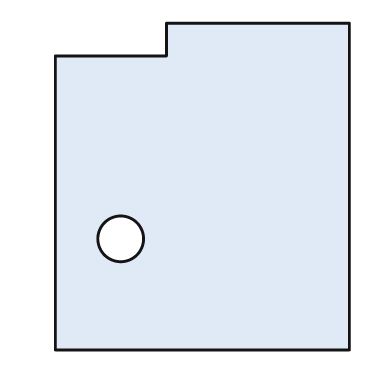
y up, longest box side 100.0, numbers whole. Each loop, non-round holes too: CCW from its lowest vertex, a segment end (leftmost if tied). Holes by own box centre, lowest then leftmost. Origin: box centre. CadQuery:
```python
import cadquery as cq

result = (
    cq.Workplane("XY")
    .moveTo(-45.0, -50.0)
    .lineTo(45.0, -50.0)
    .lineTo(45.0, 50.0)
    .lineTo(-11.0, 50.0)
    .lineTo(-11.0, 40.0)
    .lineTo(-45.0, 40.0)
    .close()
    .moveTo(-25.0, -16.0)
    .circle(7.0)
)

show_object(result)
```